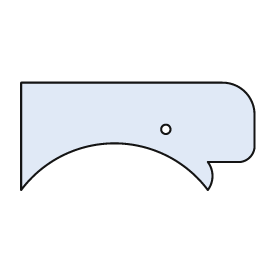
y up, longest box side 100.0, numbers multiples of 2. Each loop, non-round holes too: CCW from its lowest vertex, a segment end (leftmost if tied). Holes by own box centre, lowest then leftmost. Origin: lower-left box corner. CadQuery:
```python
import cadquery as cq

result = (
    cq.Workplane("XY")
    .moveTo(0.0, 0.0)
    .threePointArc((40.0, 20.0), (80.0, 0.0))
    .threePointArc((82.0, 6.0), (80.0, 12.0))
    .lineTo(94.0, 12.0)
    .threePointArc((98.0, 14.0), (100.0, 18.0))
    .lineTo(100.0, 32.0)
    .threePointArc((96.0, 42.0), (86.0, 46.0))
    .lineTo(0.0, 46.0)
    .close()
    .moveTo(62.0, 26.0)
    .circle(2.0)
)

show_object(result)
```